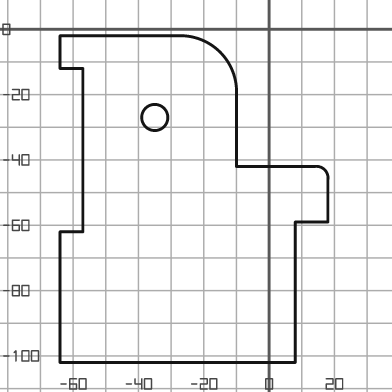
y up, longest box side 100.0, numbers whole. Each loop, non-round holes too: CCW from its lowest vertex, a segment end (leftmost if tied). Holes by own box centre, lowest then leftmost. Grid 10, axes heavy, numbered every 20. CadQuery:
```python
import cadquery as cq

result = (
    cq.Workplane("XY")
    .moveTo(-64.0, -102.0)
    .lineTo(8.0, -102.0)
    .lineTo(8.0, -59.0)
    .lineTo(18.0, -59.0)
    .lineTo(18.0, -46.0)
    .threePointArc((17.0, -43.0), (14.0, -42.0))
    .lineTo(-10.0, -42.0)
    .lineTo(-10.0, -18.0)
    .threePointArc((-15.0, -7.0), (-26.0, -2.0))
    .lineTo(-64.0, -2.0)
    .lineTo(-64.0, -12.0)
    .lineTo(-57.0, -12.0)
    .lineTo(-57.0, -62.0)
    .lineTo(-64.0, -62.0)
    .close()
    .moveTo(-35.0, -27.0)
    .circle(4.0)
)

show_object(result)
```